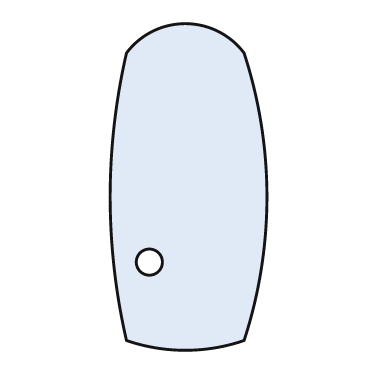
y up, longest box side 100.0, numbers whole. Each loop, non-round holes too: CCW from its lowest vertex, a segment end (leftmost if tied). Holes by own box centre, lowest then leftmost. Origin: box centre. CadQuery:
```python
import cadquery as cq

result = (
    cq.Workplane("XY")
    .moveTo(-19.0, -47.0)
    .threePointArc((-1.0, -50.0), (17.0, -47.0))
    .threePointArc((24.0, -3.0), (17.0, 41.0))
    .threePointArc((-1.0, 50.0), (-19.0, 41.0))
    .threePointArc((-24.0, -3.0), (-19.0, -47.0))
    .close()
    .moveTo(-12.0, -23.0)
    .circle(4.0)
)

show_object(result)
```